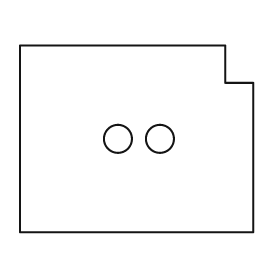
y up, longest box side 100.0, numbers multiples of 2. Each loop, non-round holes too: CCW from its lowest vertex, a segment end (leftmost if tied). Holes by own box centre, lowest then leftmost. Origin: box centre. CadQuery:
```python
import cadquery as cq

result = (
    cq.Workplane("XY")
    .moveTo(-50.0, -40.0)
    .lineTo(50.0, -40.0)
    .lineTo(50.0, 24.0)
    .lineTo(38.0, 24.0)
    .lineTo(38.0, 40.0)
    .lineTo(-50.0, 40.0)
    .close()
    .moveTo(-8.0, 0.0)
    .circle(6.0)
    .moveTo(10.0, 0.0)
    .circle(6.0)
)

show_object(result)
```